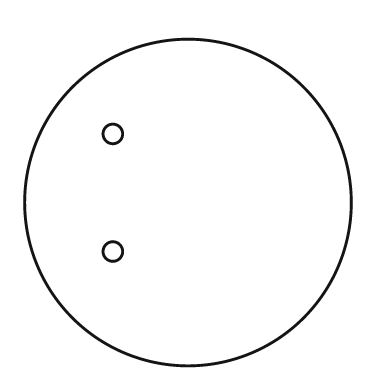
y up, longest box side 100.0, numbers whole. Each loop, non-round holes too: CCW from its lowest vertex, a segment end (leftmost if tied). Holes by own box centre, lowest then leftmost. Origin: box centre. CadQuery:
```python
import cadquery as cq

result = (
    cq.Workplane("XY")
    .moveTo(0.0, 0.0)
    .circle(50.0)
    .moveTo(-23.0, -15.0)
    .circle(3.0)
    .moveTo(-23.0, 21.0)
    .circle(3.0)
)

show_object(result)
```